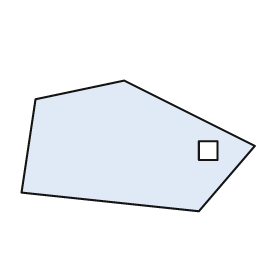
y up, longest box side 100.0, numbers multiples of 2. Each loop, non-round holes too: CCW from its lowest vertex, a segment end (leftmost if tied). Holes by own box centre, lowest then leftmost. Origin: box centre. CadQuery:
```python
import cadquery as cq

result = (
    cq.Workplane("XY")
    .moveTo(26.0, -28.0)
    .lineTo(50.0, 0.0)
    .lineTo(-6.0, 28.0)
    .lineTo(-44.0, 20.0)
    .lineTo(-50.0, -20.0)
    .close()
    .moveTo(26.0, -6.0)
    .lineTo(34.0, -6.0)
    .lineTo(34.0, 2.0)
    .lineTo(26.0, 2.0)
    .close()
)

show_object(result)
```